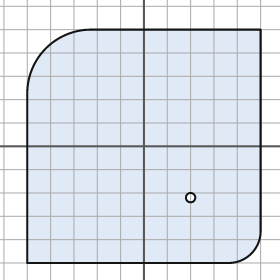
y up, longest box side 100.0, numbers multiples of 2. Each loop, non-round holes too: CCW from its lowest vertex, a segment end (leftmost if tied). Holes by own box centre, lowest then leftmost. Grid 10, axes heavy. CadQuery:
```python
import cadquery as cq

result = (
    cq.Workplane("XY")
    .moveTo(-50.0, -50.0)
    .lineTo(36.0, -50.0)
    .threePointArc((46.0, -46.0), (50.0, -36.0))
    .lineTo(50.0, 50.0)
    .lineTo(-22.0, 50.0)
    .threePointArc((-42.0, 42.0), (-50.0, 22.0))
    .close()
    .moveTo(20.0, -22.0)
    .circle(2.0)
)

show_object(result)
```